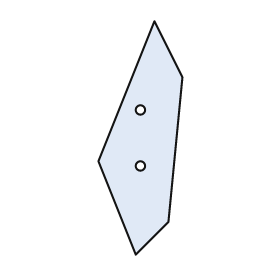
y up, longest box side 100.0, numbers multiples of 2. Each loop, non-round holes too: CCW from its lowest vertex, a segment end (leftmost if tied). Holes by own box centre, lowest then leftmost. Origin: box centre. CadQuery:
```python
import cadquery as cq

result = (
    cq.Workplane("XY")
    .moveTo(-2.0, -50.0)
    .lineTo(12.0, -36.0)
    .lineTo(18.0, 26.0)
    .lineTo(6.0, 50.0)
    .lineTo(-18.0, -10.0)
    .close()
    .moveTo(0.0, -12.0)
    .circle(2.0)
    .moveTo(0.0, 12.0)
    .circle(2.0)
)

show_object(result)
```